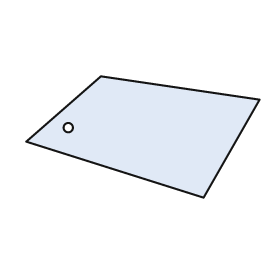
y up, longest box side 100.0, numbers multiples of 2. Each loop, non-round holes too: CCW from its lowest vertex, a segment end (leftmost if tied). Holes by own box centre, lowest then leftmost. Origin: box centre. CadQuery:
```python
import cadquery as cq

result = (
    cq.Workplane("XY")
    .moveTo(26.0, -26.0)
    .lineTo(50.0, 16.0)
    .lineTo(-18.0, 26.0)
    .lineTo(-50.0, -2.0)
    .close()
    .moveTo(-32.0, 4.0)
    .circle(2.0)
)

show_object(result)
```